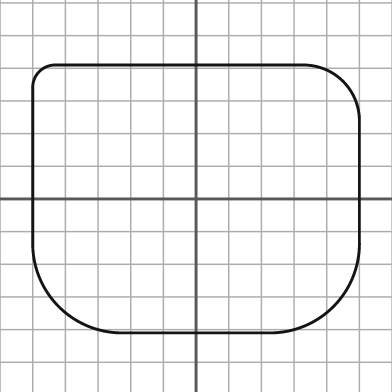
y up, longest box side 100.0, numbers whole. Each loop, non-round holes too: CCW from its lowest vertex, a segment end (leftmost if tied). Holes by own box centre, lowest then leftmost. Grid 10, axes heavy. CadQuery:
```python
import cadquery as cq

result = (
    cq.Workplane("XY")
    .moveTo(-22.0, -41.0)
    .lineTo(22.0, -41.0)
    .threePointArc((42.0, -33.0), (50.0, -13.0))
    .lineTo(50.0, 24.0)
    .threePointArc((45.0, 36.0), (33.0, 41.0))
    .lineTo(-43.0, 41.0)
    .threePointArc((-48.0, 39.0), (-50.0, 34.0))
    .lineTo(-50.0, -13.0)
    .threePointArc((-42.0, -33.0), (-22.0, -41.0))
    .close()
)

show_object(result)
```